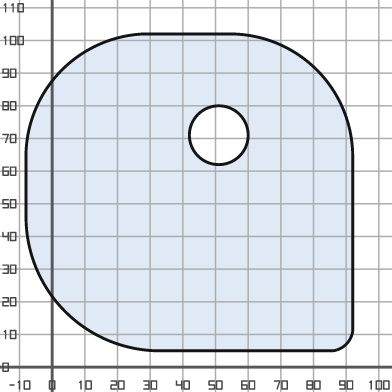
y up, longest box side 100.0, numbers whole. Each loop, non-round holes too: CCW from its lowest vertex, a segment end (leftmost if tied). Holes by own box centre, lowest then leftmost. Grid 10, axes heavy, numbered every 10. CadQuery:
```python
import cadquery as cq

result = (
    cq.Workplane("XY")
    .moveTo(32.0, 5.0)
    .lineTo(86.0, 5.0)
    .threePointArc((90.0, 7.0), (92.0, 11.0))
    .lineTo(92.0, 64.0)
    .threePointArc((81.0, 91.0), (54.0, 102.0))
    .lineTo(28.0, 102.0)
    .threePointArc((3.0, 91.0), (-8.0, 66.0))
    .lineTo(-8.0, 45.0)
    .threePointArc((4.0, 17.0), (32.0, 5.0))
    .close()
    .moveTo(51.0, 71.0)
    .circle(9.0)
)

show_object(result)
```